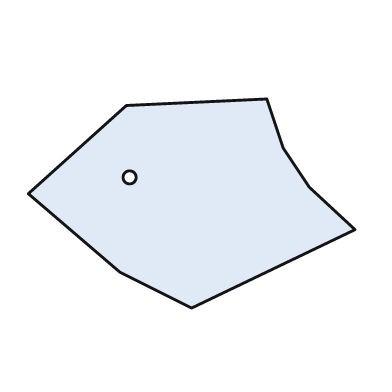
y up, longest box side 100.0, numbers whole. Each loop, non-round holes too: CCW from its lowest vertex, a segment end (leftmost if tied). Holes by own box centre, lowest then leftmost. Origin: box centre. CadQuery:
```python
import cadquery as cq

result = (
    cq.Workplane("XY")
    .moveTo(0.0, -32.0)
    .lineTo(50.0, -8.0)
    .lineTo(36.0, 5.0)
    .lineTo(28.0, 17.0)
    .lineTo(23.0, 32.0)
    .lineTo(-20.0, 30.0)
    .lineTo(-50.0, 3.0)
    .lineTo(-22.0, -21.0)
    .close()
    .moveTo(-19.0, 8.0)
    .circle(2.0)
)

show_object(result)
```